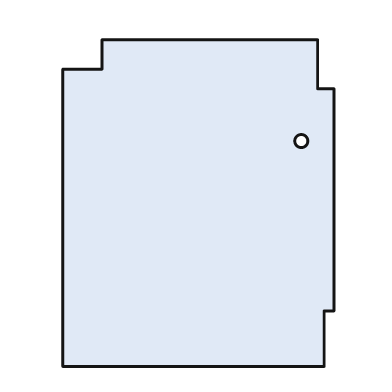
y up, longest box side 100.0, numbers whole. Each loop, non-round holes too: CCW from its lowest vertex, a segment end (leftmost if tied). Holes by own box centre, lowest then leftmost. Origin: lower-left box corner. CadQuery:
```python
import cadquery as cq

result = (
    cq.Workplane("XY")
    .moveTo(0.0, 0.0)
    .lineTo(80.0, 0.0)
    .lineTo(80.0, 17.0)
    .lineTo(83.0, 17.0)
    .lineTo(83.0, 85.0)
    .lineTo(78.0, 85.0)
    .lineTo(78.0, 100.0)
    .lineTo(12.0, 100.0)
    .lineTo(12.0, 91.0)
    .lineTo(0.0, 91.0)
    .close()
    .moveTo(73.0, 69.0)
    .circle(2.0)
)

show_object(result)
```